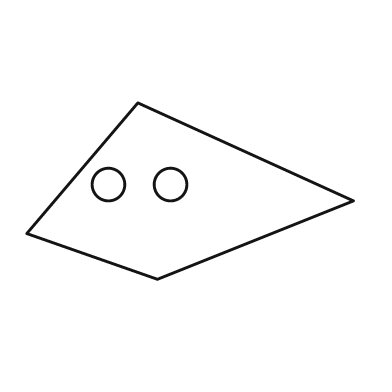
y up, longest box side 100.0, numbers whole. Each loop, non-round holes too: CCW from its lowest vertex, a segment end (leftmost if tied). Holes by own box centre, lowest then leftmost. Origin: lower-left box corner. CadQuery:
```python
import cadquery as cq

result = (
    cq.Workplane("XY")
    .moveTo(40.0, 0.0)
    .lineTo(100.0, 24.0)
    .lineTo(34.0, 54.0)
    .lineTo(0.0, 14.0)
    .close()
    .moveTo(25.0, 29.0)
    .circle(5.0)
    .moveTo(44.0, 29.0)
    .circle(5.0)
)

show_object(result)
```